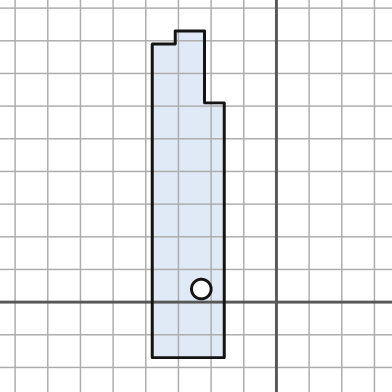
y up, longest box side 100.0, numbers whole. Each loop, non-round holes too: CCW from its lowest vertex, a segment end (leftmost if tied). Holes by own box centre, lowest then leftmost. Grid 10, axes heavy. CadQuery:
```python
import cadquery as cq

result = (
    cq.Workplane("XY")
    .moveTo(-38.0, -17.0)
    .lineTo(-16.0, -17.0)
    .lineTo(-16.0, 61.0)
    .lineTo(-22.0, 61.0)
    .lineTo(-22.0, 83.0)
    .lineTo(-31.0, 83.0)
    .lineTo(-31.0, 79.0)
    .lineTo(-38.0, 79.0)
    .close()
    .moveTo(-23.0, 4.0)
    .circle(3.0)
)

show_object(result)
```